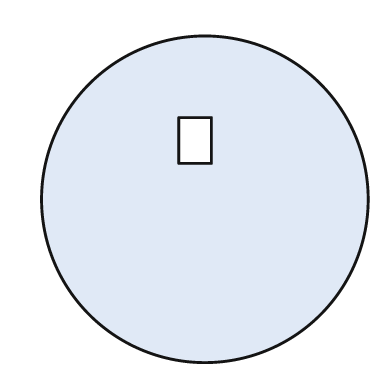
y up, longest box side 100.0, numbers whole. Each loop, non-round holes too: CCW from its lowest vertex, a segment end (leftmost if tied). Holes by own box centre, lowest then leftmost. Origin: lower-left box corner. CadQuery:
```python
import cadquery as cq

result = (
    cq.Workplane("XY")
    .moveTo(50.0, 50.0)
    .circle(50.0)
    .moveTo(42.0, 61.0)
    .lineTo(52.0, 61.0)
    .lineTo(52.0, 75.0)
    .lineTo(42.0, 75.0)
    .close()
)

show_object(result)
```